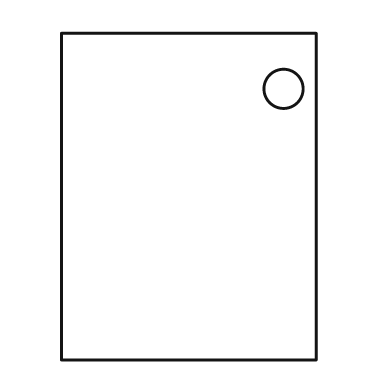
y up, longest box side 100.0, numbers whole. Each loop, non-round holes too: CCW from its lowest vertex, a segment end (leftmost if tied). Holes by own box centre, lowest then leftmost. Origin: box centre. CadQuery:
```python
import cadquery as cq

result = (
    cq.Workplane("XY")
    .moveTo(-39.0, -50.0)
    .lineTo(39.0, -50.0)
    .lineTo(39.0, 50.0)
    .lineTo(-39.0, 50.0)
    .close()
    .moveTo(29.0, 33.0)
    .circle(6.0)
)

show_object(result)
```